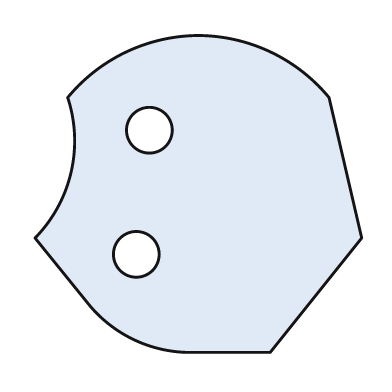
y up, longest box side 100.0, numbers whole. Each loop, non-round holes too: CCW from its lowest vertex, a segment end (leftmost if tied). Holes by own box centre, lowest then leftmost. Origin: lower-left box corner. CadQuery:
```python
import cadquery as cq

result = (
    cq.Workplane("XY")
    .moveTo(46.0, 0.0)
    .lineTo(72.0, 0.0)
    .lineTo(100.0, 35.0)
    .lineTo(90.0, 78.0)
    .threePointArc((72.0, 92.0), (50.0, 97.0))
    .threePointArc((28.0, 92.0), (10.0, 78.0))
    .threePointArc((11.0, 55.0), (0.0, 35.0))
    .lineTo(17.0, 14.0)
    .threePointArc((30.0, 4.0), (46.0, 0.0))
    .close()
    .moveTo(31.0, 30.0)
    .circle(7.0)
    .moveTo(35.0, 68.0)
    .circle(7.0)
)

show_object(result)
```